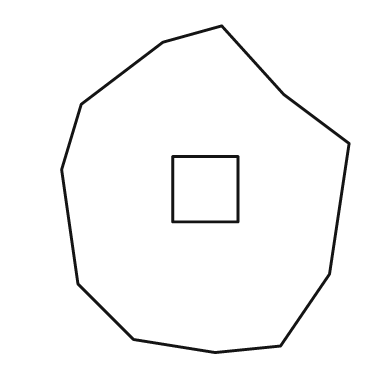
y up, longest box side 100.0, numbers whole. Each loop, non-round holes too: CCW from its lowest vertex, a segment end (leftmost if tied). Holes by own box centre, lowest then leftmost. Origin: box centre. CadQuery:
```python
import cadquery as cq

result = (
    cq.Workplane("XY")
    .moveTo(3.0, -50.0)
    .lineTo(23.0, -48.0)
    .lineTo(38.0, -26.0)
    .lineTo(44.0, 14.0)
    .lineTo(24.0, 29.0)
    .lineTo(5.0, 50.0)
    .lineTo(-13.0, 45.0)
    .lineTo(-38.0, 26.0)
    .lineTo(-44.0, 6.0)
    .lineTo(-39.0, -29.0)
    .lineTo(-22.0, -46.0)
    .close()
    .moveTo(-10.0, -10.0)
    .lineTo(10.0, -10.0)
    .lineTo(10.0, 10.0)
    .lineTo(-10.0, 10.0)
    .close()
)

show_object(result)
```